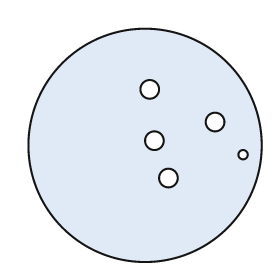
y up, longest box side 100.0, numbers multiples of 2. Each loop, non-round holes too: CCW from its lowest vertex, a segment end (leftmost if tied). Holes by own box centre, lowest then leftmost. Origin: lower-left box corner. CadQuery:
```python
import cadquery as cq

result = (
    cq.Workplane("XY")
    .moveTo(50.0, 50.0)
    .circle(50.0)
    .moveTo(60.0, 36.0)
    .circle(4.0)
    .moveTo(92.0, 46.0)
    .circle(2.0)
    .moveTo(54.0, 52.0)
    .circle(4.0)
    .moveTo(80.0, 60.0)
    .circle(4.0)
    .moveTo(52.0, 74.0)
    .circle(4.0)
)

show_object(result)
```